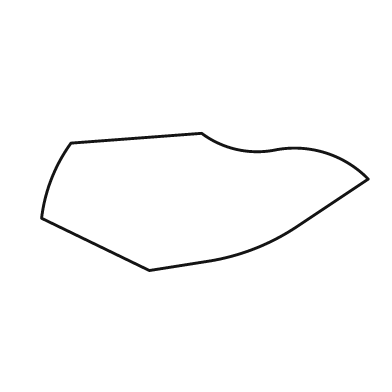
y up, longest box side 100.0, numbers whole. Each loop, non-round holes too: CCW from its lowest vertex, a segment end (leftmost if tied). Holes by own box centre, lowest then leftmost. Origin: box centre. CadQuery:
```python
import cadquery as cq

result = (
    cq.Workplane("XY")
    .moveTo(-17.0, -21.0)
    .lineTo(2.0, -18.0)
    .threePointArc((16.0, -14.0), (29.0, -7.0))
    .lineTo(50.0, 7.0)
    .threePointArc((37.0, 15.0), (22.0, 16.0))
    .threePointArc((10.0, 16.0), (-1.0, 21.0))
    .lineTo(-41.0, 18.0)
    .threePointArc((-47.0, 7.0), (-50.0, -5.0))
    .close()
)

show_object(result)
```